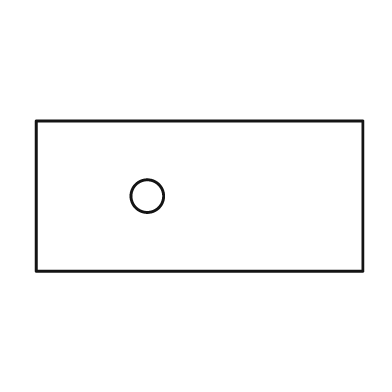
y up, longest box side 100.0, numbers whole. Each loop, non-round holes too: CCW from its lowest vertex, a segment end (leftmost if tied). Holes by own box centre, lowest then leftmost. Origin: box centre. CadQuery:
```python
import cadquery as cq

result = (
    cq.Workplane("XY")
    .moveTo(-50.0, -23.0)
    .lineTo(50.0, -23.0)
    .lineTo(50.0, 23.0)
    .lineTo(-50.0, 23.0)
    .close()
    .moveTo(-16.0, 0.0)
    .circle(5.0)
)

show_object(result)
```